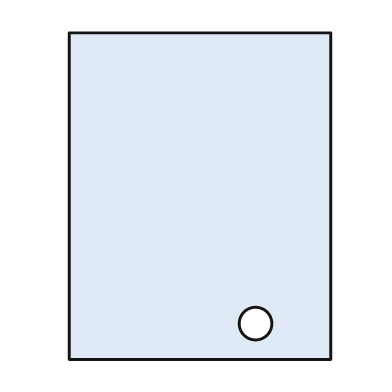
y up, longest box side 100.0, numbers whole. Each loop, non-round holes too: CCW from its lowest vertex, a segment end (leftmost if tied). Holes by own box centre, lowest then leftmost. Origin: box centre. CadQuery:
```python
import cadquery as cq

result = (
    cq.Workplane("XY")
    .moveTo(-40.0, -50.0)
    .lineTo(40.0, -50.0)
    .lineTo(40.0, 50.0)
    .lineTo(-40.0, 50.0)
    .close()
    .moveTo(17.0, -39.0)
    .circle(5.0)
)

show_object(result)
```